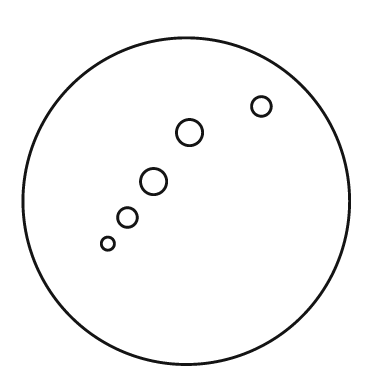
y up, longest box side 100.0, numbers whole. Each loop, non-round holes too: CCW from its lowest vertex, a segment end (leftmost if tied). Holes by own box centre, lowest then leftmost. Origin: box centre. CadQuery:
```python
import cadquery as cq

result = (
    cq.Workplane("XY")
    .moveTo(0.0, 0.0)
    .circle(50.0)
    .moveTo(-24.0, -13.0)
    .circle(2.0)
    .moveTo(-18.0, -5.0)
    .circle(3.0)
    .moveTo(-10.0, 6.0)
    .circle(4.0)
    .moveTo(1.0, 21.0)
    .circle(4.0)
    .moveTo(23.0, 29.0)
    .circle(3.0)
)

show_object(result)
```